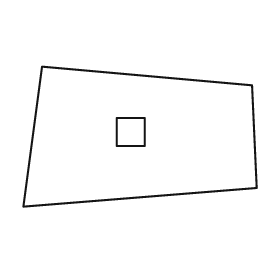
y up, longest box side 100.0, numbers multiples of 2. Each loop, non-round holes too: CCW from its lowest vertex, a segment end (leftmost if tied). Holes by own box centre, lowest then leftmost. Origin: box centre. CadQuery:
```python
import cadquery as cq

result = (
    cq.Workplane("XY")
    .moveTo(-50.0, -30.0)
    .lineTo(50.0, -22.0)
    .lineTo(48.0, 22.0)
    .lineTo(-42.0, 30.0)
    .close()
    .moveTo(-10.0, -4.0)
    .lineTo(2.0, -4.0)
    .lineTo(2.0, 8.0)
    .lineTo(-10.0, 8.0)
    .close()
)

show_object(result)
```